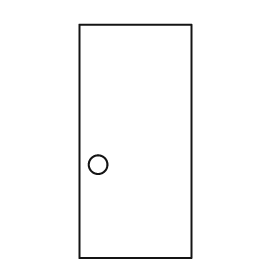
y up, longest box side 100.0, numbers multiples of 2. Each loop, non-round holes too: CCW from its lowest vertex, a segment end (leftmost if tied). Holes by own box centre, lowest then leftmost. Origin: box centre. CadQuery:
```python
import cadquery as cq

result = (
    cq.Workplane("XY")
    .moveTo(-24.0, -50.0)
    .lineTo(24.0, -50.0)
    .lineTo(24.0, 50.0)
    .lineTo(-24.0, 50.0)
    .close()
    .moveTo(-16.0, -10.0)
    .circle(4.0)
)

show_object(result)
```